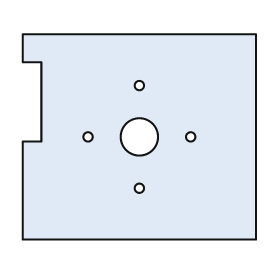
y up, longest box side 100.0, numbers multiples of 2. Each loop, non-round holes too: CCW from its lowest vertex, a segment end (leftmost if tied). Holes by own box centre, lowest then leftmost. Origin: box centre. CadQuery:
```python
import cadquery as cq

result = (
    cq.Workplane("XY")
    .moveTo(-50.0, -44.0)
    .lineTo(50.0, -44.0)
    .lineTo(50.0, 44.0)
    .lineTo(-50.0, 44.0)
    .lineTo(-50.0, 32.0)
    .lineTo(-42.0, 32.0)
    .lineTo(-42.0, -2.0)
    .lineTo(-50.0, -2.0)
    .close()
    .moveTo(0.0, -22.0)
    .circle(2.0)
    .moveTo(-22.0, 0.0)
    .circle(2.0)
    .moveTo(0.0, 0.0)
    .circle(8.0)
    .moveTo(22.0, 0.0)
    .circle(2.0)
    .moveTo(0.0, 22.0)
    .circle(2.0)
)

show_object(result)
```